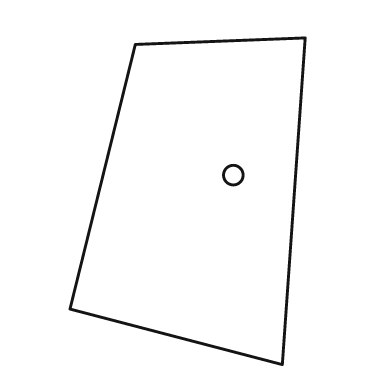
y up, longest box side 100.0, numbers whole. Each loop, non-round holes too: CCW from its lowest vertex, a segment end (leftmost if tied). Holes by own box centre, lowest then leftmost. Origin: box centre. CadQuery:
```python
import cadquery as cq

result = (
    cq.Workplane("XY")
    .moveTo(29.0, -50.0)
    .lineTo(36.0, 50.0)
    .lineTo(-16.0, 48.0)
    .lineTo(-36.0, -33.0)
    .close()
    .moveTo(14.0, 8.0)
    .circle(3.0)
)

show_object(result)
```